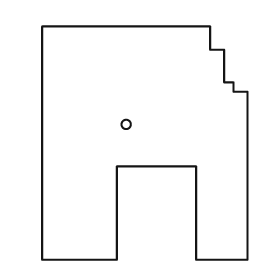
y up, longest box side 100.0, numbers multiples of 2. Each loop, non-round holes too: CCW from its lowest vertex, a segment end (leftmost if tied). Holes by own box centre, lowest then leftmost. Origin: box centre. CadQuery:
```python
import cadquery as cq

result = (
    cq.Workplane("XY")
    .moveTo(-44.0, -50.0)
    .lineTo(-12.0, -50.0)
    .lineTo(-12.0, -10.0)
    .lineTo(22.0, -10.0)
    .lineTo(22.0, -50.0)
    .lineTo(44.0, -50.0)
    .lineTo(44.0, 22.0)
    .lineTo(38.0, 22.0)
    .lineTo(38.0, 26.0)
    .lineTo(34.0, 26.0)
    .lineTo(34.0, 40.0)
    .lineTo(28.0, 40.0)
    .lineTo(28.0, 50.0)
    .lineTo(-44.0, 50.0)
    .close()
    .moveTo(-8.0, 8.0)
    .circle(2.0)
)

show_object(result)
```